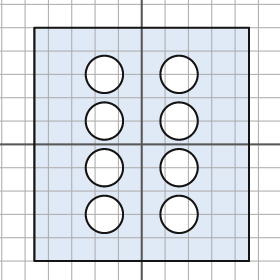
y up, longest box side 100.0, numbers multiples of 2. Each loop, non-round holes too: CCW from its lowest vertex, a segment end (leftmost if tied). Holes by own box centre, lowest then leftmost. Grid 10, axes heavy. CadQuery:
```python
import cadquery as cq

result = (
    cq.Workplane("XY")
    .moveTo(-46.0, -50.0)
    .lineTo(46.0, -50.0)
    .lineTo(46.0, 50.0)
    .lineTo(-46.0, 50.0)
    .close()
    .moveTo(-16.0, -30.0)
    .circle(8.0)
    .moveTo(16.0, -30.0)
    .circle(8.0)
    .moveTo(-16.0, -10.0)
    .circle(8.0)
    .moveTo(16.0, -10.0)
    .circle(8.0)
    .moveTo(-16.0, 10.0)
    .circle(8.0)
    .moveTo(16.0, 10.0)
    .circle(8.0)
    .moveTo(-16.0, 30.0)
    .circle(8.0)
    .moveTo(16.0, 30.0)
    .circle(8.0)
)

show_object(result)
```